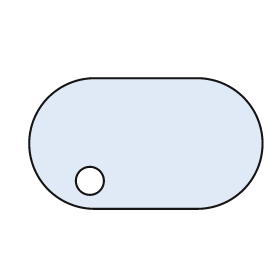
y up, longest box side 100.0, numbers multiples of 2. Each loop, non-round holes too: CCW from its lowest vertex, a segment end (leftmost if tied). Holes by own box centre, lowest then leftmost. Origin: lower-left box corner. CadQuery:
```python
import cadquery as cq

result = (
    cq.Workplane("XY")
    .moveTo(28.0, 0.0)
    .lineTo(72.0, 0.0)
    .threePointArc((100.0, 28.0), (72.0, 56.0))
    .lineTo(28.0, 56.0)
    .threePointArc((0.0, 28.0), (28.0, 0.0))
    .close()
    .moveTo(26.0, 12.0)
    .circle(6.0)
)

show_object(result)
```